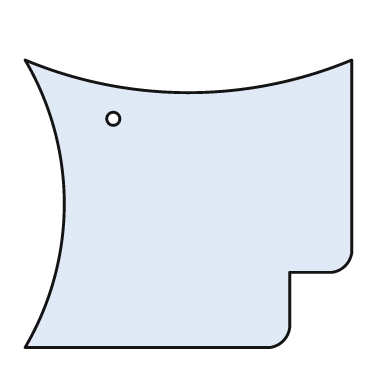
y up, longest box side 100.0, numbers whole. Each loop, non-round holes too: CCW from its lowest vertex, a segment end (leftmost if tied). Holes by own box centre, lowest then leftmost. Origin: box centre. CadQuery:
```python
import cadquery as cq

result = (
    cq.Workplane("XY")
    .moveTo(-50.0, -44.0)
    .lineTo(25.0, -44.0)
    .threePointArc((29.0, -42.0), (31.0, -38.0))
    .lineTo(31.0, -21.0)
    .lineTo(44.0, -21.0)
    .threePointArc((48.0, -19.0), (50.0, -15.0))
    .lineTo(50.0, 44.0)
    .threePointArc((0.0, 34.0), (-50.0, 44.0))
    .threePointArc((-38.0, 0.0), (-50.0, -44.0))
    .close()
    .moveTo(-23.0, 26.0)
    .circle(2.0)
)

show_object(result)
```